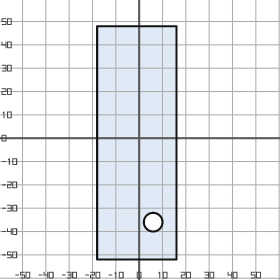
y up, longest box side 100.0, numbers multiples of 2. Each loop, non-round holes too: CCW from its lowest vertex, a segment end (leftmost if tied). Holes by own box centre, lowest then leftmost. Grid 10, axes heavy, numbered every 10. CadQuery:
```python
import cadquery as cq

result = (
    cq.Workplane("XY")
    .moveTo(-18.0, -52.0)
    .lineTo(16.0, -52.0)
    .lineTo(16.0, 48.0)
    .lineTo(-18.0, 48.0)
    .close()
    .moveTo(6.0, -36.0)
    .circle(4.0)
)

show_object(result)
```